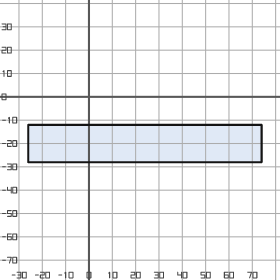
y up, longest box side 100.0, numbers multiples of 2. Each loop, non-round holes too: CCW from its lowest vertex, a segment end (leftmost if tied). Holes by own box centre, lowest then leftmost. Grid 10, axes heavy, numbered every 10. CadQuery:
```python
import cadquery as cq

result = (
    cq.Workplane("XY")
    .moveTo(-26.0, -28.0)
    .lineTo(74.0, -28.0)
    .lineTo(74.0, -12.0)
    .lineTo(-26.0, -12.0)
    .close()
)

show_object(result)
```